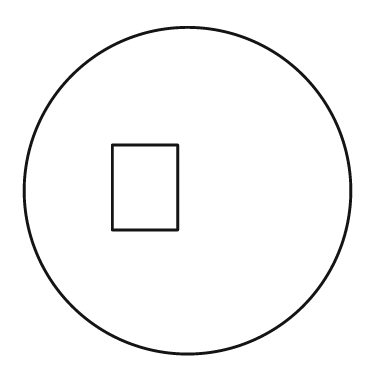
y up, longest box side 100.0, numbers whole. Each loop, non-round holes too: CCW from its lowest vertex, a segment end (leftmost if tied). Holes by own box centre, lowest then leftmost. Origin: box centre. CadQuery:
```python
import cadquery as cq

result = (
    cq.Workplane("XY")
    .moveTo(0.0, 0.0)
    .circle(50.0)
    .moveTo(-23.0, -12.0)
    .lineTo(-3.0, -12.0)
    .lineTo(-3.0, 14.0)
    .lineTo(-23.0, 14.0)
    .close()
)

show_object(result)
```